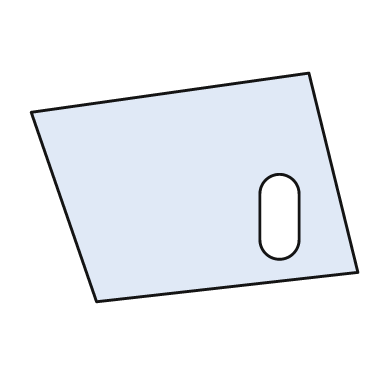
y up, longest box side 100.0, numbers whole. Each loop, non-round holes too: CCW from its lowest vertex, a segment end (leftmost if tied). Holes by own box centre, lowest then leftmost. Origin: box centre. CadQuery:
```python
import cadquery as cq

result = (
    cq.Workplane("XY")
    .moveTo(-30.0, -35.0)
    .lineTo(50.0, -26.0)
    .lineTo(35.0, 35.0)
    .lineTo(-50.0, 23.0)
    .close()
    .moveTo(20.0, -16.0)
    .threePointArc((26.0, -22.0), (32.0, -16.0))
    .lineTo(32.0, -2.0)
    .threePointArc((26.0, 4.0), (20.0, -2.0))
    .close()
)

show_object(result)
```